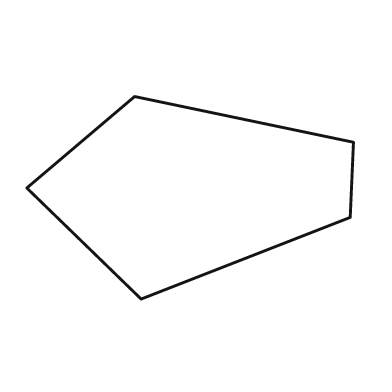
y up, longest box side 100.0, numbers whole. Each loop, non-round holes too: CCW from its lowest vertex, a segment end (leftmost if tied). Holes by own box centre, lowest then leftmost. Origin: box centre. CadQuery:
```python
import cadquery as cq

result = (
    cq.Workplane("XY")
    .moveTo(-15.0, -31.0)
    .lineTo(49.0, -6.0)
    .lineTo(50.0, 17.0)
    .lineTo(-17.0, 31.0)
    .lineTo(-50.0, 3.0)
    .close()
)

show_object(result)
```